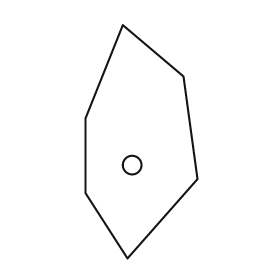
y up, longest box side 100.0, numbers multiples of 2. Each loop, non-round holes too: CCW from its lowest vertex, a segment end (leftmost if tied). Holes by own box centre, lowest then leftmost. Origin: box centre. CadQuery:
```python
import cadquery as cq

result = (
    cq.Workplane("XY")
    .moveTo(-6.0, -50.0)
    .lineTo(24.0, -16.0)
    .lineTo(18.0, 28.0)
    .lineTo(-8.0, 50.0)
    .lineTo(-24.0, 10.0)
    .lineTo(-24.0, -22.0)
    .close()
    .moveTo(-4.0, -10.0)
    .circle(4.0)
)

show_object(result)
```